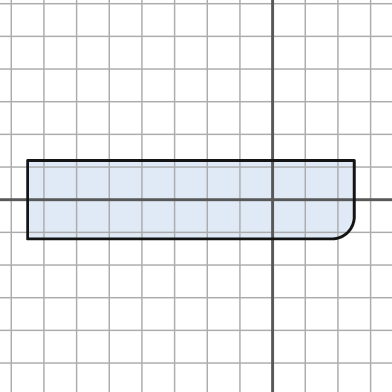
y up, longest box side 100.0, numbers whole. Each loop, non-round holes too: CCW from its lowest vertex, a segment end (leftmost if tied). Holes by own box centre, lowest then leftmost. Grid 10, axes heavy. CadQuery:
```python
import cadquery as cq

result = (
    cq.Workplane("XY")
    .moveTo(-75.0, -12.0)
    .lineTo(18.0, -12.0)
    .threePointArc((23.0, -10.0), (25.0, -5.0))
    .lineTo(25.0, 12.0)
    .lineTo(-75.0, 12.0)
    .close()
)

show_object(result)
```